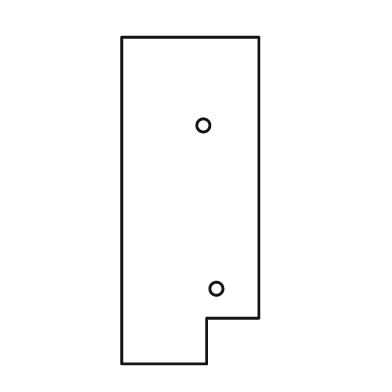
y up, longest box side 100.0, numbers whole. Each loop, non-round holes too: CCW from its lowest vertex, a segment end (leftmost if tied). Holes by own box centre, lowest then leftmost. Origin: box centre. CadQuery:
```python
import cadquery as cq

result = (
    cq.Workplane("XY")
    .moveTo(-21.0, -50.0)
    .lineTo(5.0, -50.0)
    .lineTo(5.0, -36.0)
    .lineTo(21.0, -36.0)
    .lineTo(21.0, 50.0)
    .lineTo(-21.0, 50.0)
    .close()
    .moveTo(8.0, -27.0)
    .circle(2.0)
    .moveTo(4.0, 23.0)
    .circle(2.0)
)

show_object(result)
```